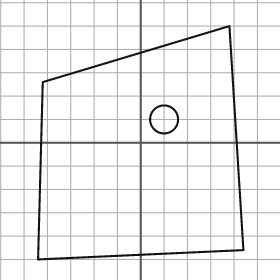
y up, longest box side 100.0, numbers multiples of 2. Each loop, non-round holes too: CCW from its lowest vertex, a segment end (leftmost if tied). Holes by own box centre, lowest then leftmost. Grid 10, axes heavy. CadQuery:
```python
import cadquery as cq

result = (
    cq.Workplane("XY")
    .moveTo(-44.0, -50.0)
    .lineTo(44.0, -46.0)
    .lineTo(38.0, 50.0)
    .lineTo(-42.0, 26.0)
    .close()
    .moveTo(10.0, 10.0)
    .circle(6.0)
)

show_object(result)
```